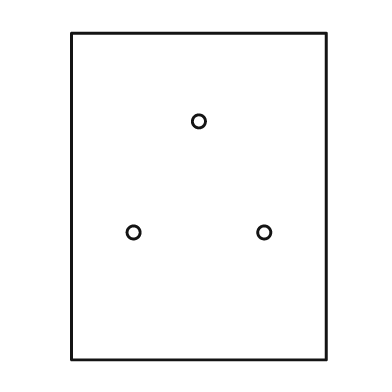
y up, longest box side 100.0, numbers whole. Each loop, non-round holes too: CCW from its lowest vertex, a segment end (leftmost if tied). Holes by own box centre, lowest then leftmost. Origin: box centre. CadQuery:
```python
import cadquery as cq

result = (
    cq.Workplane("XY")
    .moveTo(-39.0, -50.0)
    .lineTo(39.0, -50.0)
    .lineTo(39.0, 50.0)
    .lineTo(-39.0, 50.0)
    .close()
    .moveTo(-20.0, -11.0)
    .circle(2.0)
    .moveTo(20.0, -11.0)
    .circle(2.0)
    .moveTo(0.0, 23.0)
    .circle(2.0)
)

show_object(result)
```